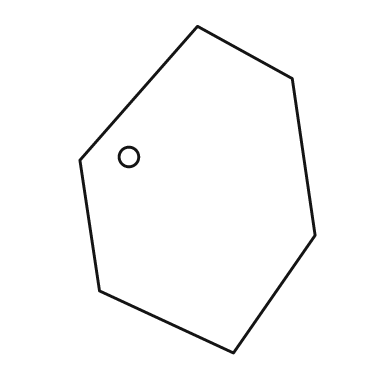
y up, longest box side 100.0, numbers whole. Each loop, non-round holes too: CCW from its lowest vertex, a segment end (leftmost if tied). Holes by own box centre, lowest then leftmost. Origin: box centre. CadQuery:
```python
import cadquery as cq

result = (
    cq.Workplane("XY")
    .moveTo(11.0, -50.0)
    .lineTo(36.0, -14.0)
    .lineTo(29.0, 34.0)
    .lineTo(0.0, 50.0)
    .lineTo(-36.0, 9.0)
    .lineTo(-30.0, -31.0)
    .close()
    .moveTo(-21.0, 10.0)
    .circle(3.0)
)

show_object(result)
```